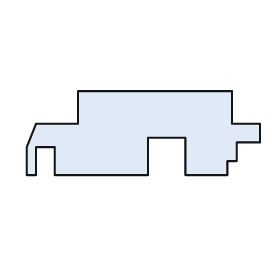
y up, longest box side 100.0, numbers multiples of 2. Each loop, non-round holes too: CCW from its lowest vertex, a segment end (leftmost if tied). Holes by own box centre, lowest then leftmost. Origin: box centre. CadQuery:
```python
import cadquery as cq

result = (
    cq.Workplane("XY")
    .moveTo(-50.0, -18.0)
    .lineTo(-46.0, -18.0)
    .lineTo(-46.0, -6.0)
    .lineTo(-38.0, -6.0)
    .lineTo(-38.0, -18.0)
    .lineTo(2.0, -18.0)
    .lineTo(2.0, -2.0)
    .lineTo(18.0, -2.0)
    .lineTo(18.0, -18.0)
    .lineTo(36.0, -18.0)
    .lineTo(36.0, -12.0)
    .lineTo(40.0, -12.0)
    .lineTo(40.0, -4.0)
    .lineTo(50.0, -4.0)
    .lineTo(50.0, 4.0)
    .lineTo(38.0, 4.0)
    .lineTo(38.0, 18.0)
    .lineTo(-28.0, 18.0)
    .lineTo(-28.0, 4.0)
    .lineTo(-46.0, 4.0)
    .lineTo(-50.0, -6.0)
    .close()
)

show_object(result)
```